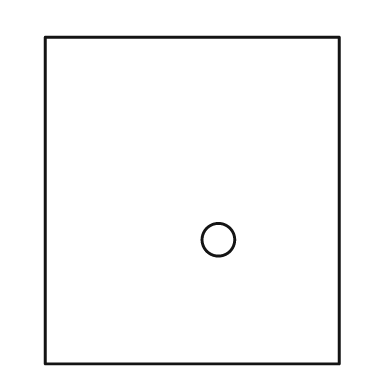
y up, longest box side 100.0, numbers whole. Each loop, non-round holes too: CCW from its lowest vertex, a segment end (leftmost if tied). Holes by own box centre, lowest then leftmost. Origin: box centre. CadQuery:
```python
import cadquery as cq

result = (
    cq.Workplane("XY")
    .moveTo(-45.0, -50.0)
    .lineTo(45.0, -50.0)
    .lineTo(45.0, 50.0)
    .lineTo(-45.0, 50.0)
    .close()
    .moveTo(8.0, -12.0)
    .circle(5.0)
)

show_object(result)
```